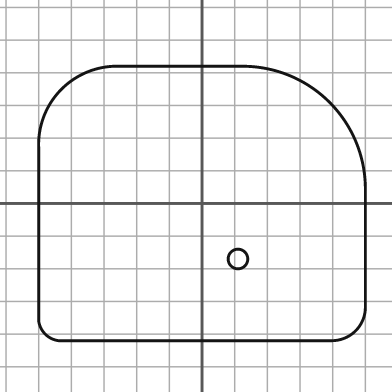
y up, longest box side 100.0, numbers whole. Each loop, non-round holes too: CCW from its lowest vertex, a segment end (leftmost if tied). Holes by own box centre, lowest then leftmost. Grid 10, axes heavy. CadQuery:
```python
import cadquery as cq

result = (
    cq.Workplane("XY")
    .moveTo(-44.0, -42.0)
    .lineTo(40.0, -42.0)
    .threePointArc((47.0, -39.0), (50.0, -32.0))
    .lineTo(50.0, 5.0)
    .threePointArc((39.0, 31.0), (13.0, 42.0))
    .lineTo(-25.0, 42.0)
    .threePointArc((-43.0, 35.0), (-50.0, 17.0))
    .lineTo(-50.0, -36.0)
    .threePointArc((-48.0, -40.0), (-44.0, -42.0))
    .close()
    .moveTo(11.0, -17.0)
    .circle(3.0)
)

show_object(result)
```